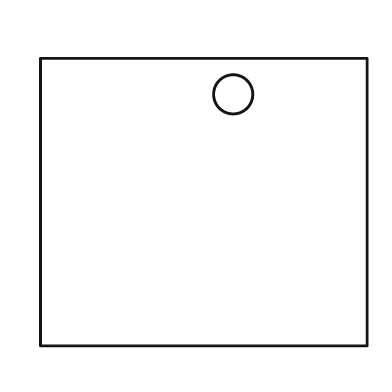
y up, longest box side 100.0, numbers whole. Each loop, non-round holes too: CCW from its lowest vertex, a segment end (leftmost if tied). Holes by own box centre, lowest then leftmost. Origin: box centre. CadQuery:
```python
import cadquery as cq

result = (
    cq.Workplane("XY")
    .moveTo(-50.0, -44.0)
    .lineTo(50.0, -44.0)
    .lineTo(50.0, 44.0)
    .lineTo(-50.0, 44.0)
    .close()
    .moveTo(9.0, 33.0)
    .circle(6.0)
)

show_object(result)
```